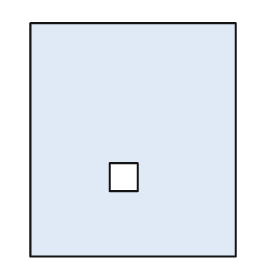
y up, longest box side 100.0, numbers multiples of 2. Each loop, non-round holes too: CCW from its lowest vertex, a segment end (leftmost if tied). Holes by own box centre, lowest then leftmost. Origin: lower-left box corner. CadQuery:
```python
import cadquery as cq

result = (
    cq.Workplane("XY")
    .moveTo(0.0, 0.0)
    .lineTo(88.0, 0.0)
    .lineTo(88.0, 100.0)
    .lineTo(0.0, 100.0)
    .close()
    .moveTo(34.0, 28.0)
    .lineTo(46.0, 28.0)
    .lineTo(46.0, 40.0)
    .lineTo(34.0, 40.0)
    .close()
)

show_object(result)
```